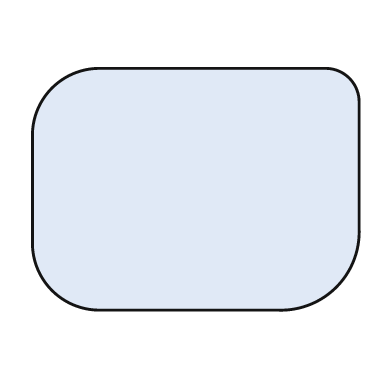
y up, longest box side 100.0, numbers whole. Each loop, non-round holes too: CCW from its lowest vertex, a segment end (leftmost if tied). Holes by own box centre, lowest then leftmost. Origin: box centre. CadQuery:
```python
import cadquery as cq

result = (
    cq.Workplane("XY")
    .moveTo(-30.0, -37.0)
    .lineTo(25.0, -37.0)
    .threePointArc((43.0, -30.0), (50.0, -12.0))
    .lineTo(50.0, 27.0)
    .threePointArc((47.0, 34.0), (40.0, 37.0))
    .lineTo(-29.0, 37.0)
    .threePointArc((-44.0, 31.0), (-50.0, 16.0))
    .lineTo(-50.0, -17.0)
    .threePointArc((-44.0, -31.0), (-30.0, -37.0))
    .close()
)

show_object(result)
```